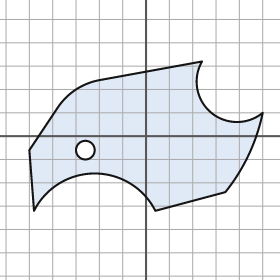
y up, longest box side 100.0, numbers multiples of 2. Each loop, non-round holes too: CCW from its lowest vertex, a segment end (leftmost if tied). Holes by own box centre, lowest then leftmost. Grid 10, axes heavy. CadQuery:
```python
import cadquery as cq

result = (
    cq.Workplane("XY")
    .moveTo(-48.0, -32.0)
    .threePointArc((-22.0, -16.0), (4.0, -32.0))
    .lineTo(34.0, -24.0)
    .threePointArc((44.0, -8.0), (50.0, 10.0))
    .threePointArc((28.0, 10.0), (24.0, 32.0))
    .lineTo(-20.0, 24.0)
    .threePointArc((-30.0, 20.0), (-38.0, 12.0))
    .lineTo(-50.0, -6.0)
    .close()
    .moveTo(-26.0, -6.0)
    .circle(4.0)
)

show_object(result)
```